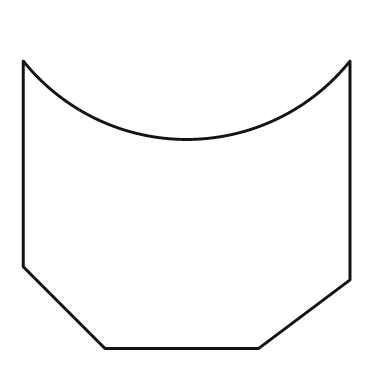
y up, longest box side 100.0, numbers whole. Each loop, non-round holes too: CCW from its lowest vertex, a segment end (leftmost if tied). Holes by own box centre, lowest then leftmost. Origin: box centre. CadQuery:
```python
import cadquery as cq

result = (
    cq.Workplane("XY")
    .moveTo(-25.0, -44.0)
    .lineTo(22.0, -44.0)
    .lineTo(50.0, -23.0)
    .lineTo(50.0, 44.0)
    .threePointArc((0.0, 20.0), (-50.0, 44.0))
    .lineTo(-50.0, -19.0)
    .close()
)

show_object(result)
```